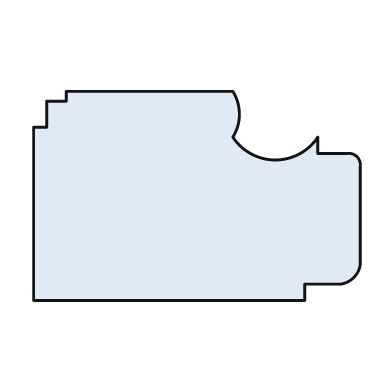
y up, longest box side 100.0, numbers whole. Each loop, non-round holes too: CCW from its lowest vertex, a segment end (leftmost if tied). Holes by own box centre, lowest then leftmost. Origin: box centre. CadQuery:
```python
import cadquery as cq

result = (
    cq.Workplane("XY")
    .moveTo(-50.0, -32.0)
    .lineTo(33.0, -32.0)
    .lineTo(33.0, -27.0)
    .lineTo(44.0, -27.0)
    .threePointArc((48.0, -25.0), (50.0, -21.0))
    .lineTo(50.0, 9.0)
    .threePointArc((49.0, 12.0), (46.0, 13.0))
    .lineTo(37.0, 13.0)
    .lineTo(37.0, 18.0)
    .threePointArc((24.0, 11.0), (11.0, 18.0))
    .threePointArc((13.0, 25.0), (11.0, 32.0))
    .lineTo(-40.0, 32.0)
    .lineTo(-40.0, 29.0)
    .lineTo(-46.0, 29.0)
    .lineTo(-46.0, 21.0)
    .lineTo(-50.0, 21.0)
    .close()
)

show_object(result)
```